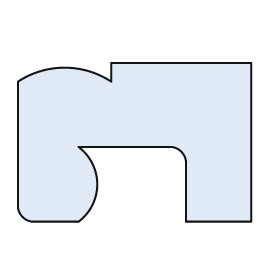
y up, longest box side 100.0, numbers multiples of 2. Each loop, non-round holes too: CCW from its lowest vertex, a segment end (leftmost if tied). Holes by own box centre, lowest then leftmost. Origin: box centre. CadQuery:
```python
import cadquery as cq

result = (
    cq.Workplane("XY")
    .moveTo(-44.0, -34.0)
    .lineTo(-24.0, -34.0)
    .threePointArc((-16.0, -18.0), (-24.0, -2.0))
    .lineTo(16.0, -2.0)
    .threePointArc((20.0, -4.0), (22.0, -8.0))
    .lineTo(22.0, -34.0)
    .lineTo(50.0, -34.0)
    .lineTo(50.0, 34.0)
    .lineTo(-10.0, 34.0)
    .lineTo(-10.0, 26.0)
    .threePointArc((-30.0, 32.0), (-50.0, 26.0))
    .lineTo(-50.0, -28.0)
    .threePointArc((-48.0, -32.0), (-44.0, -34.0))
    .close()
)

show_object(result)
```